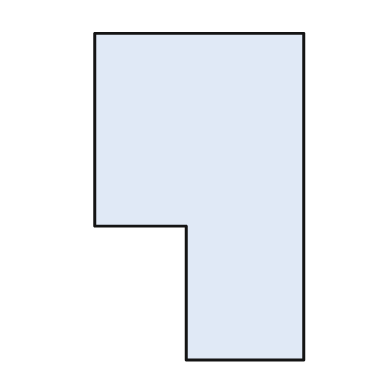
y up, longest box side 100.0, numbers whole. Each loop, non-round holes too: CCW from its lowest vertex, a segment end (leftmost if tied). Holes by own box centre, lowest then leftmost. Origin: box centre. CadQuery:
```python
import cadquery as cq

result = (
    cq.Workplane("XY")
    .moveTo(-4.0, -50.0)
    .lineTo(32.0, -50.0)
    .lineTo(32.0, 50.0)
    .lineTo(-32.0, 50.0)
    .lineTo(-32.0, -9.0)
    .lineTo(-4.0, -9.0)
    .close()
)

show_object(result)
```